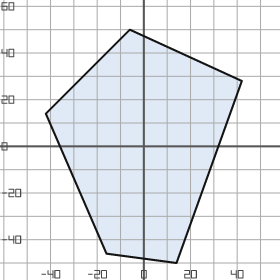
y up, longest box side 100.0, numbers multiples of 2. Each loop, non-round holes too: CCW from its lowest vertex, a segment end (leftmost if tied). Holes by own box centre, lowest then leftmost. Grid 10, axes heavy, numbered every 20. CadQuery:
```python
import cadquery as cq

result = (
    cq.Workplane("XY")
    .moveTo(14.0, -50.0)
    .lineTo(42.0, 28.0)
    .lineTo(-6.0, 50.0)
    .lineTo(-42.0, 14.0)
    .lineTo(-16.0, -46.0)
    .close()
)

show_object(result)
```